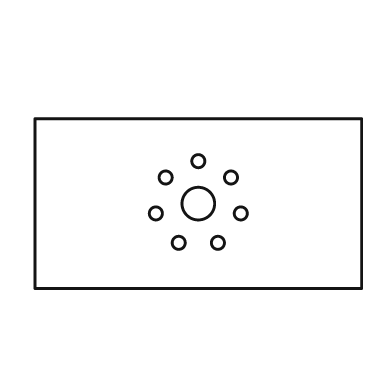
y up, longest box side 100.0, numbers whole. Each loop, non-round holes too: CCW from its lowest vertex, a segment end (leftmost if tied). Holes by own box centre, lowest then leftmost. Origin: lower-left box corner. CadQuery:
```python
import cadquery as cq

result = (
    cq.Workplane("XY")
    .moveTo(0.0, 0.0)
    .lineTo(100.0, 0.0)
    .lineTo(100.0, 52.0)
    .lineTo(0.0, 52.0)
    .close()
    .moveTo(44.0, 14.0)
    .circle(2.0)
    .moveTo(56.0, 14.0)
    .circle(2.0)
    .moveTo(37.0, 23.0)
    .circle(2.0)
    .moveTo(63.0, 23.0)
    .circle(2.0)
    .moveTo(50.0, 26.0)
    .circle(5.0)
    .moveTo(40.0, 34.0)
    .circle(2.0)
    .moveTo(60.0, 34.0)
    .circle(2.0)
    .moveTo(50.0, 39.0)
    .circle(2.0)
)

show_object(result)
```